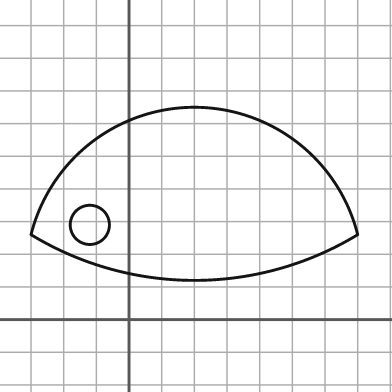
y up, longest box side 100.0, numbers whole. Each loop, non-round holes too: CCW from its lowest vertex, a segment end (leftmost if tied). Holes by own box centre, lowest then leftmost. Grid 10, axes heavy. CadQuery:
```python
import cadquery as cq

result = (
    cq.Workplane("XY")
    .moveTo(-30.0, 26.0)
    .threePointArc((20.0, 12.0), (70.0, 26.0))
    .threePointArc((20.0, 65.0), (-30.0, 26.0))
    .close()
    .moveTo(-12.0, 29.0)
    .circle(6.0)
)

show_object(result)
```